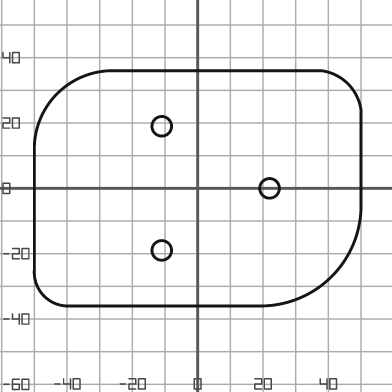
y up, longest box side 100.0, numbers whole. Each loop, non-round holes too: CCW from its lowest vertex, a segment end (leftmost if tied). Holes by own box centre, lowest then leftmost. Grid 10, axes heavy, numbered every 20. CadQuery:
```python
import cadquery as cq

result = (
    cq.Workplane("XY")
    .moveTo(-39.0, -36.0)
    .lineTo(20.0, -36.0)
    .threePointArc((41.0, -27.0), (50.0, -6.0))
    .lineTo(50.0, 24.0)
    .threePointArc((46.0, 32.0), (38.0, 36.0))
    .lineTo(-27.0, 36.0)
    .threePointArc((-43.0, 29.0), (-50.0, 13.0))
    .lineTo(-50.0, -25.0)
    .threePointArc((-47.0, -33.0), (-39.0, -36.0))
    .close()
    .moveTo(-11.0, -19.0)
    .circle(3.0)
    .moveTo(22.0, 0.0)
    .circle(3.0)
    .moveTo(-11.0, 19.0)
    .circle(3.0)
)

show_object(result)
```